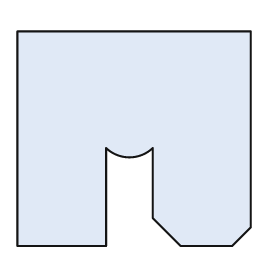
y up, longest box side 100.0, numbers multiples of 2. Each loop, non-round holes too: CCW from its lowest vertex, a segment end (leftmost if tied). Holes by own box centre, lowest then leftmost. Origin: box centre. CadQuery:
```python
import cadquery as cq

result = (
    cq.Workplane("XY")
    .moveTo(-50.0, -46.0)
    .lineTo(-12.0, -46.0)
    .lineTo(-12.0, -4.0)
    .threePointArc((-2.0, -8.0), (8.0, -4.0))
    .lineTo(8.0, -34.0)
    .lineTo(20.0, -46.0)
    .lineTo(42.0, -46.0)
    .lineTo(50.0, -38.0)
    .lineTo(50.0, 46.0)
    .lineTo(-50.0, 46.0)
    .close()
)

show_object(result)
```